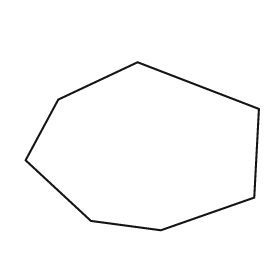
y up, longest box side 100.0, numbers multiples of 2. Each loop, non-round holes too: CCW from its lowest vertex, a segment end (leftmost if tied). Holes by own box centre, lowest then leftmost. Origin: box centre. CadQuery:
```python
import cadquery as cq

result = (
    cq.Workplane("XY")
    .moveTo(8.0, -36.0)
    .lineTo(48.0, -22.0)
    .lineTo(50.0, 16.0)
    .lineTo(-2.0, 36.0)
    .lineTo(-36.0, 20.0)
    .lineTo(-50.0, -6.0)
    .lineTo(-22.0, -32.0)
    .close()
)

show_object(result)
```